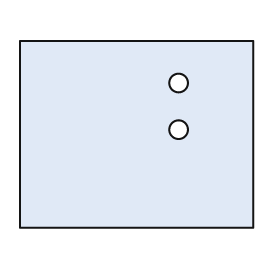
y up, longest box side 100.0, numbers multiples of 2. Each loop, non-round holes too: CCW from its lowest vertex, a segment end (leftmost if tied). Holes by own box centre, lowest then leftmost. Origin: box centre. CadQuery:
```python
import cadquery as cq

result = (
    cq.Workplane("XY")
    .moveTo(-50.0, -40.0)
    .lineTo(50.0, -40.0)
    .lineTo(50.0, 40.0)
    .lineTo(-50.0, 40.0)
    .close()
    .moveTo(18.0, 2.0)
    .circle(4.0)
    .moveTo(18.0, 22.0)
    .circle(4.0)
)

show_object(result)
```